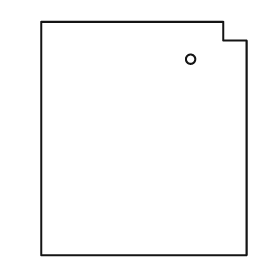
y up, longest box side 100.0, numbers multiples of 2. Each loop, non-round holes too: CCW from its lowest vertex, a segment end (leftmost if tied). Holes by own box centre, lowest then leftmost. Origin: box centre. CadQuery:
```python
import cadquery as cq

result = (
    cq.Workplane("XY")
    .moveTo(-44.0, -50.0)
    .lineTo(44.0, -50.0)
    .lineTo(44.0, 42.0)
    .lineTo(34.0, 42.0)
    .lineTo(34.0, 50.0)
    .lineTo(-44.0, 50.0)
    .close()
    .moveTo(20.0, 34.0)
    .circle(2.0)
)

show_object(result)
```